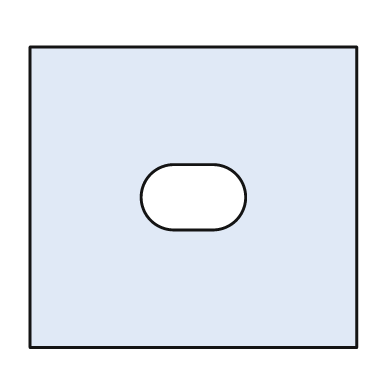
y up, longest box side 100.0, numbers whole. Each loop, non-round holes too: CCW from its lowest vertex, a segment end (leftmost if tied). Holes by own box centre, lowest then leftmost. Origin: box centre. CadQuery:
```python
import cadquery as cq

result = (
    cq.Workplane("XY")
    .moveTo(-50.0, -46.0)
    .lineTo(50.0, -46.0)
    .lineTo(50.0, 46.0)
    .lineTo(-50.0, 46.0)
    .close()
    .moveTo(-6.0, -10.0)
    .lineTo(6.0, -10.0)
    .threePointArc((16.0, 0.0), (6.0, 10.0))
    .lineTo(-6.0, 10.0)
    .threePointArc((-16.0, 0.0), (-6.0, -10.0))
    .close()
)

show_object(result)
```